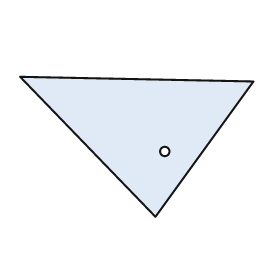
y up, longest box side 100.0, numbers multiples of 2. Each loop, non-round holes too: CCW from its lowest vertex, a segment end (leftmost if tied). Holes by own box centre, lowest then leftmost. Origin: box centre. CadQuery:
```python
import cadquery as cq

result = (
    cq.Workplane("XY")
    .moveTo(8.0, -30.0)
    .lineTo(50.0, 28.0)
    .lineTo(-50.0, 30.0)
    .close()
    .moveTo(12.0, -2.0)
    .circle(2.0)
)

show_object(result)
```